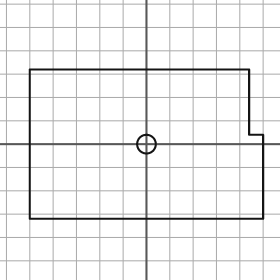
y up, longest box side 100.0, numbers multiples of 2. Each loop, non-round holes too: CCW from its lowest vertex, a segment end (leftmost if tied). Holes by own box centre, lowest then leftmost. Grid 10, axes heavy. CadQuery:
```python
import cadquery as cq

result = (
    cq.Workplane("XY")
    .moveTo(-50.0, -32.0)
    .lineTo(50.0, -32.0)
    .lineTo(50.0, 4.0)
    .lineTo(44.0, 4.0)
    .lineTo(44.0, 32.0)
    .lineTo(-50.0, 32.0)
    .close()
    .moveTo(0.0, 0.0)
    .circle(4.0)
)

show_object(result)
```